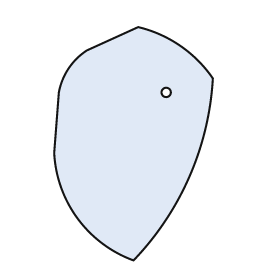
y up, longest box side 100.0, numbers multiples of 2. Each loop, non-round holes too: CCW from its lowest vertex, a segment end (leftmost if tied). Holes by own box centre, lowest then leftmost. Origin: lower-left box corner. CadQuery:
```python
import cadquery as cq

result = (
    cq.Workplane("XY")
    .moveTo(34.0, 0.0)
    .threePointArc((58.0, 36.0), (68.0, 78.0))
    .threePointArc((54.0, 92.0), (36.0, 100.0))
    .lineTo(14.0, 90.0)
    .threePointArc((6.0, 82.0), (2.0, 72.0))
    .lineTo(0.0, 46.0)
    .threePointArc((10.0, 18.0), (34.0, 0.0))
    .close()
    .moveTo(48.0, 72.0)
    .circle(2.0)
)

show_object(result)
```